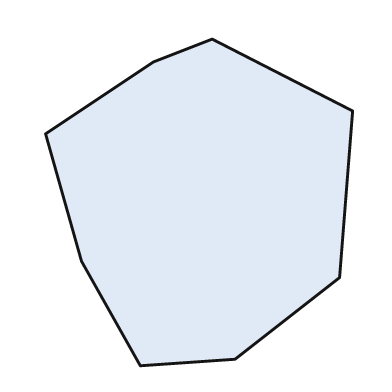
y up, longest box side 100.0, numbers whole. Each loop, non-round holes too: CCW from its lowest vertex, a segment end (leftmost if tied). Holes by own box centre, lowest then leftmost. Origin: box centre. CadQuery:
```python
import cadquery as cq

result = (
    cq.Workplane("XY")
    .moveTo(-18.0, -50.0)
    .lineTo(11.0, -48.0)
    .lineTo(43.0, -23.0)
    .lineTo(47.0, 28.0)
    .lineTo(4.0, 50.0)
    .lineTo(-14.0, 43.0)
    .lineTo(-47.0, 21.0)
    .lineTo(-36.0, -18.0)
    .close()
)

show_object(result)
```